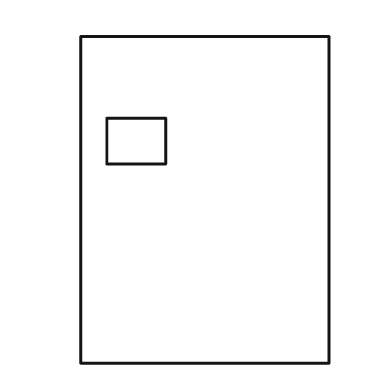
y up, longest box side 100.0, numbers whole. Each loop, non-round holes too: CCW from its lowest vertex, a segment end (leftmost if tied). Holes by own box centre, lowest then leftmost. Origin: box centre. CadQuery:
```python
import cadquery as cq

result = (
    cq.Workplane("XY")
    .moveTo(-38.0, -50.0)
    .lineTo(38.0, -50.0)
    .lineTo(38.0, 50.0)
    .lineTo(-38.0, 50.0)
    .close()
    .moveTo(-30.0, 11.0)
    .lineTo(-12.0, 11.0)
    .lineTo(-12.0, 25.0)
    .lineTo(-30.0, 25.0)
    .close()
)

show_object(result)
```